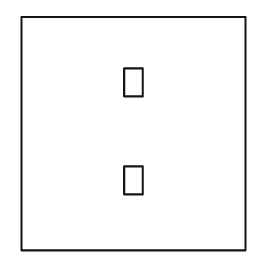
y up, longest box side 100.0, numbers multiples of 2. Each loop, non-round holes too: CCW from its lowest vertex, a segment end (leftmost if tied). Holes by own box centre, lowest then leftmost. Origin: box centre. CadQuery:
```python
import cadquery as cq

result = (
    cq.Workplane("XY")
    .moveTo(-48.0, -50.0)
    .lineTo(48.0, -50.0)
    .lineTo(48.0, 50.0)
    .lineTo(-48.0, 50.0)
    .close()
    .moveTo(-4.0, -26.0)
    .lineTo(4.0, -26.0)
    .lineTo(4.0, -14.0)
    .lineTo(-4.0, -14.0)
    .close()
    .moveTo(-4.0, 16.0)
    .lineTo(4.0, 16.0)
    .lineTo(4.0, 28.0)
    .lineTo(-4.0, 28.0)
    .close()
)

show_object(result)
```